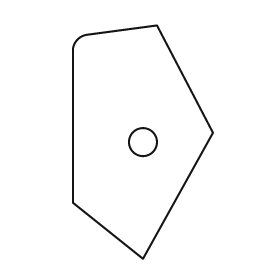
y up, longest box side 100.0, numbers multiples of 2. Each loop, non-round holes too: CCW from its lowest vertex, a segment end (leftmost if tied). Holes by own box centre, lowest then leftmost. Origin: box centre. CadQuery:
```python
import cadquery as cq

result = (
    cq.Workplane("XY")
    .moveTo(0.0, -50.0)
    .lineTo(30.0, 4.0)
    .lineTo(6.0, 50.0)
    .lineTo(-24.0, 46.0)
    .threePointArc((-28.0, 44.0), (-30.0, 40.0))
    .lineTo(-30.0, -26.0)
    .close()
    .moveTo(0.0, 0.0)
    .circle(6.0)
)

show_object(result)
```